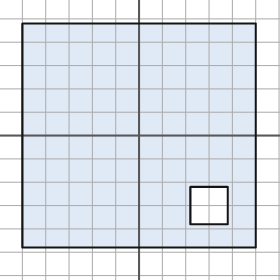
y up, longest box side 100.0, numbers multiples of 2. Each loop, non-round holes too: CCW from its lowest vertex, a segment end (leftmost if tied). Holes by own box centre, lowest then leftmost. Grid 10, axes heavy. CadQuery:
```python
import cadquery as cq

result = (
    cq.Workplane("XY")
    .moveTo(-50.0, -48.0)
    .lineTo(50.0, -48.0)
    .lineTo(50.0, 48.0)
    .lineTo(-50.0, 48.0)
    .close()
    .moveTo(22.0, -38.0)
    .lineTo(38.0, -38.0)
    .lineTo(38.0, -22.0)
    .lineTo(22.0, -22.0)
    .close()
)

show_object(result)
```